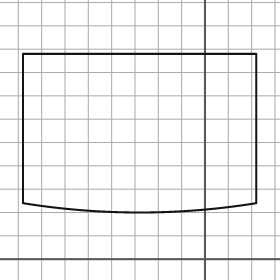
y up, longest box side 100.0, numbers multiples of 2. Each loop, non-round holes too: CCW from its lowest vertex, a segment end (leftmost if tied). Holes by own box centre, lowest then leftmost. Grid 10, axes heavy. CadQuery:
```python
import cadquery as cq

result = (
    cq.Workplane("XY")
    .moveTo(-78.0, 24.0)
    .threePointArc((-28.0, 20.0), (22.0, 24.0))
    .lineTo(22.0, 88.0)
    .lineTo(-78.0, 88.0)
    .close()
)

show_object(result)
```